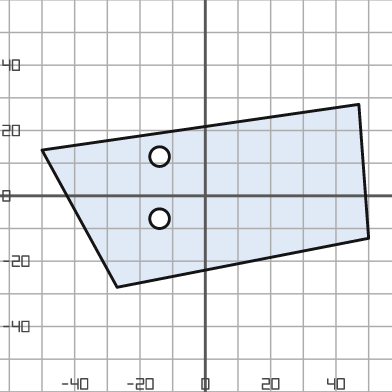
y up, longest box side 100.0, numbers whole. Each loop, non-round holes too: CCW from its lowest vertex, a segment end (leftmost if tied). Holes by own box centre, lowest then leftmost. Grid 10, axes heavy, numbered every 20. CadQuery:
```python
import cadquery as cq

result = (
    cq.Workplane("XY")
    .moveTo(-27.0, -28.0)
    .lineTo(50.0, -13.0)
    .lineTo(47.0, 28.0)
    .lineTo(-50.0, 14.0)
    .close()
    .moveTo(-14.0, -7.0)
    .circle(3.0)
    .moveTo(-14.0, 12.0)
    .circle(3.0)
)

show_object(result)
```